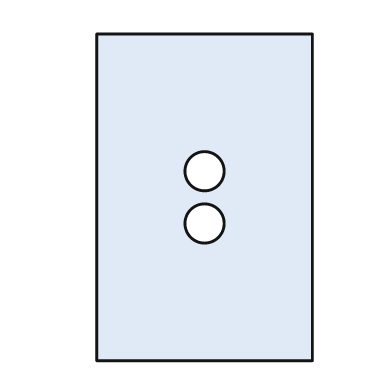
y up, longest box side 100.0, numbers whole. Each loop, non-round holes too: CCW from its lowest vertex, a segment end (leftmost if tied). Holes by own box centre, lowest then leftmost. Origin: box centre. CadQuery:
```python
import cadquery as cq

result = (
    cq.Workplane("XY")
    .moveTo(-33.0, -50.0)
    .lineTo(33.0, -50.0)
    .lineTo(33.0, 50.0)
    .lineTo(-33.0, 50.0)
    .close()
    .moveTo(0.0, -8.0)
    .circle(6.0)
    .moveTo(0.0, 8.0)
    .circle(6.0)
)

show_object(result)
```